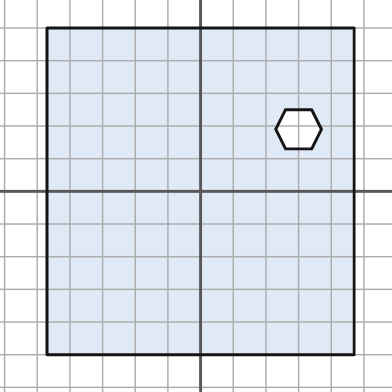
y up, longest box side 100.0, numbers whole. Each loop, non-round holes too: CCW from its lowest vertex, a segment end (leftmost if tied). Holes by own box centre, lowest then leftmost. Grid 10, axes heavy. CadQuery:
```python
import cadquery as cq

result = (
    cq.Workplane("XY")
    .moveTo(-47.0, -50.0)
    .lineTo(47.0, -50.0)
    .lineTo(47.0, 50.0)
    .lineTo(-47.0, 50.0)
    .close()
    .moveTo(26.0, 13.0)
    .lineTo(34.0, 13.0)
    .lineTo(37.0, 19.0)
    .lineTo(34.0, 25.0)
    .lineTo(26.0, 25.0)
    .lineTo(23.0, 19.0)
    .close()
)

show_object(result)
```